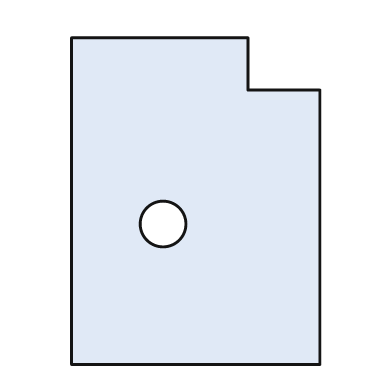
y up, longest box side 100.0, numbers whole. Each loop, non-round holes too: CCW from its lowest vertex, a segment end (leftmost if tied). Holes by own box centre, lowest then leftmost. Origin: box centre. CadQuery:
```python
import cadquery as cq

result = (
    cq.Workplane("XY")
    .moveTo(-38.0, -50.0)
    .lineTo(38.0, -50.0)
    .lineTo(38.0, 34.0)
    .lineTo(16.0, 34.0)
    .lineTo(16.0, 50.0)
    .lineTo(-38.0, 50.0)
    .close()
    .moveTo(-10.0, -7.0)
    .circle(7.0)
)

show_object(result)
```